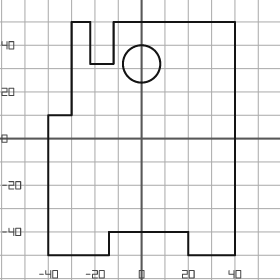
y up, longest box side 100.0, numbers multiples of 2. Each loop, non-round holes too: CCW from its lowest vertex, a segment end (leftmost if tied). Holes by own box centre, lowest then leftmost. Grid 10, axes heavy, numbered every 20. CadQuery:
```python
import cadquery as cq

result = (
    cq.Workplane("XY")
    .moveTo(-40.0, -50.0)
    .lineTo(-14.0, -50.0)
    .lineTo(-14.0, -40.0)
    .lineTo(20.0, -40.0)
    .lineTo(20.0, -50.0)
    .lineTo(40.0, -50.0)
    .lineTo(40.0, 50.0)
    .lineTo(-12.0, 50.0)
    .lineTo(-12.0, 32.0)
    .lineTo(-22.0, 32.0)
    .lineTo(-22.0, 50.0)
    .lineTo(-30.0, 50.0)
    .lineTo(-30.0, 10.0)
    .lineTo(-40.0, 10.0)
    .close()
    .moveTo(0.0, 32.0)
    .circle(8.0)
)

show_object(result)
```